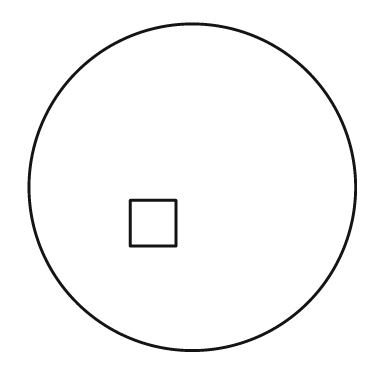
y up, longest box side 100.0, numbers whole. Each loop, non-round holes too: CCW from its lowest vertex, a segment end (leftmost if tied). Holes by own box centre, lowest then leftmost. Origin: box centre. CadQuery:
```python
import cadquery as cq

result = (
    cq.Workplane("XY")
    .moveTo(0.0, 0.0)
    .circle(50.0)
    .moveTo(-19.0, -18.0)
    .lineTo(-5.0, -18.0)
    .lineTo(-5.0, -4.0)
    .lineTo(-19.0, -4.0)
    .close()
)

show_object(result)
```